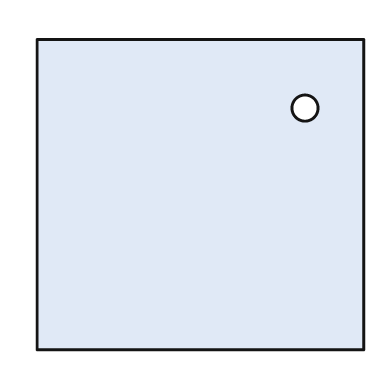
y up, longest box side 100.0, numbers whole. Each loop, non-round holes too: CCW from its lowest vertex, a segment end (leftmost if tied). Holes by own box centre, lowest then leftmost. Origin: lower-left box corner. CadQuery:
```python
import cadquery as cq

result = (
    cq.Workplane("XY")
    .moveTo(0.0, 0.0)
    .lineTo(100.0, 0.0)
    .lineTo(100.0, 95.0)
    .lineTo(0.0, 95.0)
    .close()
    .moveTo(82.0, 74.0)
    .circle(4.0)
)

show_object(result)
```